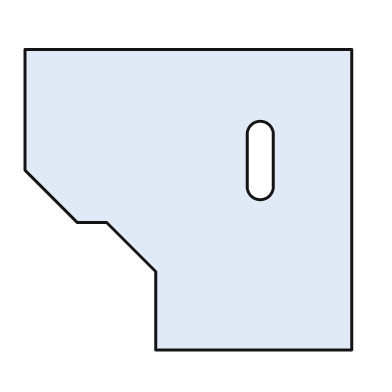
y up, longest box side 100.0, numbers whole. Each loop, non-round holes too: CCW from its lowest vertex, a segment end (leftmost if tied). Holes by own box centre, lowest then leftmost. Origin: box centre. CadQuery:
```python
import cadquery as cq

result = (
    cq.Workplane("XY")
    .moveTo(-10.0, -46.0)
    .lineTo(50.0, -46.0)
    .lineTo(50.0, 46.0)
    .lineTo(-50.0, 46.0)
    .lineTo(-50.0, 9.0)
    .lineTo(-34.0, -7.0)
    .lineTo(-25.0, -7.0)
    .lineTo(-10.0, -22.0)
    .close()
    .moveTo(18.0, 4.0)
    .threePointArc((22.0, 0.0), (26.0, 4.0))
    .lineTo(26.0, 20.0)
    .threePointArc((22.0, 24.0), (18.0, 20.0))
    .close()
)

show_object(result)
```